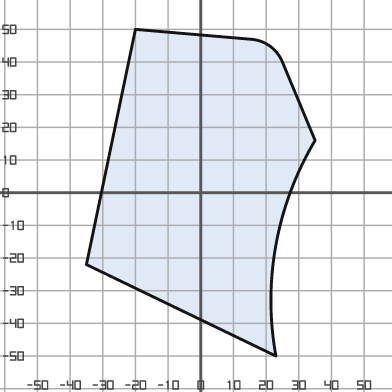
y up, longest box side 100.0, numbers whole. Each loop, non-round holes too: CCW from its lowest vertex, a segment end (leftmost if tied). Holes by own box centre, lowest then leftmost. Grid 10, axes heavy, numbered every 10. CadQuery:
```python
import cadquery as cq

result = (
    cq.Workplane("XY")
    .moveTo(23.0, -50.0)
    .threePointArc((23.0, -16.0), (35.0, 16.0))
    .lineTo(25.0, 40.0)
    .threePointArc((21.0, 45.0), (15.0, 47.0))
    .lineTo(-20.0, 50.0)
    .lineTo(-35.0, -22.0)
    .close()
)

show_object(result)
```